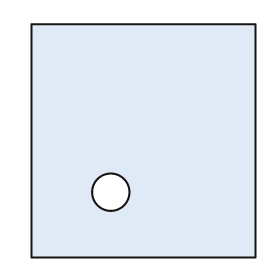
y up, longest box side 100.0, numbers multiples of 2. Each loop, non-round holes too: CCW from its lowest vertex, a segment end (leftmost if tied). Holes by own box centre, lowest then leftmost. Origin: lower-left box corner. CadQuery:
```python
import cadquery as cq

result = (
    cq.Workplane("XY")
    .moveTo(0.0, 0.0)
    .lineTo(96.0, 0.0)
    .lineTo(96.0, 100.0)
    .lineTo(0.0, 100.0)
    .close()
    .moveTo(34.0, 28.0)
    .circle(8.0)
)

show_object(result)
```